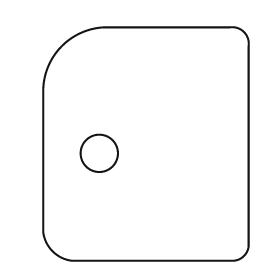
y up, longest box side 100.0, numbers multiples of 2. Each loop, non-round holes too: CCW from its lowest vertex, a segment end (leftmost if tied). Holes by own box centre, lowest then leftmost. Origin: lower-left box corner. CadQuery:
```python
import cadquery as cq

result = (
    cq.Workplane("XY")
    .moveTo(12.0, 0.0)
    .lineTo(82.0, 0.0)
    .threePointArc((86.0, 2.0), (88.0, 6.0))
    .lineTo(88.0, 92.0)
    .threePointArc((86.0, 98.0), (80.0, 100.0))
    .lineTo(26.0, 100.0)
    .threePointArc((8.0, 92.0), (0.0, 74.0))
    .lineTo(0.0, 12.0)
    .threePointArc((4.0, 4.0), (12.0, 0.0))
    .close()
    .moveTo(24.0, 46.0)
    .circle(8.0)
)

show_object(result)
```